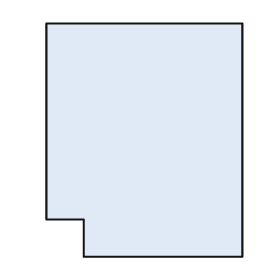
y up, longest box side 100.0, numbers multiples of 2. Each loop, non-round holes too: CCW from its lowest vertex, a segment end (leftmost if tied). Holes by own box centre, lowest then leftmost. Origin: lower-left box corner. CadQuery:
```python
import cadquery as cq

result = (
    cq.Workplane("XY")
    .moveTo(16.0, 0.0)
    .lineTo(84.0, 0.0)
    .lineTo(84.0, 100.0)
    .lineTo(0.0, 100.0)
    .lineTo(0.0, 16.0)
    .lineTo(16.0, 16.0)
    .close()
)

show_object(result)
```